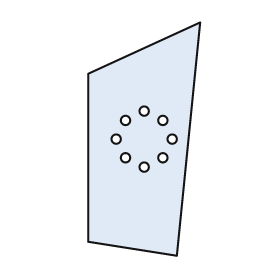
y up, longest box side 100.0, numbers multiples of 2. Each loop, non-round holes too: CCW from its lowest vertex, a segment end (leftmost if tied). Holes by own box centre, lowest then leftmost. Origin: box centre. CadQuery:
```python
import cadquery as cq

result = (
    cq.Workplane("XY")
    .moveTo(14.0, -50.0)
    .lineTo(24.0, 50.0)
    .lineTo(-24.0, 28.0)
    .lineTo(-24.0, -44.0)
    .close()
    .moveTo(0.0, -12.0)
    .circle(2.0)
    .moveTo(-8.0, -8.0)
    .circle(2.0)
    .moveTo(8.0, -8.0)
    .circle(2.0)
    .moveTo(-12.0, 0.0)
    .circle(2.0)
    .moveTo(12.0, 0.0)
    .circle(2.0)
    .moveTo(-8.0, 8.0)
    .circle(2.0)
    .moveTo(8.0, 8.0)
    .circle(2.0)
    .moveTo(0.0, 12.0)
    .circle(2.0)
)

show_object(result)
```